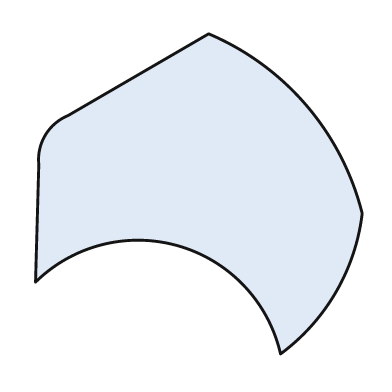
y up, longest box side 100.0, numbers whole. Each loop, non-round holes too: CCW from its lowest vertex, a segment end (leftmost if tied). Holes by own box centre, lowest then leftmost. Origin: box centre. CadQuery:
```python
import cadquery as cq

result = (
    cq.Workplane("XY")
    .moveTo(25.0, -49.0)
    .threePointArc((42.0, -30.0), (50.0, -6.0))
    .threePointArc((33.0, 27.0), (3.0, 49.0))
    .lineTo(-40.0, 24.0)
    .threePointArc((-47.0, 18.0), (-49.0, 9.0))
    .lineTo(-50.0, -27.0)
    .threePointArc((-6.0, -16.0), (25.0, -49.0))
    .close()
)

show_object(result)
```